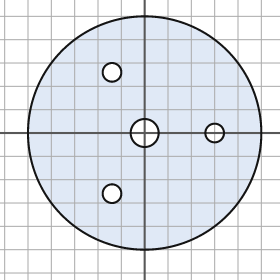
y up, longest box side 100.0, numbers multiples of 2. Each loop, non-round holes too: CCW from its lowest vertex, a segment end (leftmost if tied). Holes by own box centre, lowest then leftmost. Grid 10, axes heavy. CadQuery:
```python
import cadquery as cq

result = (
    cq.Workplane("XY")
    .moveTo(0.0, 0.0)
    .circle(50.0)
    .moveTo(-14.0, -26.0)
    .circle(4.0)
    .moveTo(0.0, 0.0)
    .circle(6.0)
    .moveTo(30.0, 0.0)
    .circle(4.0)
    .moveTo(-14.0, 26.0)
    .circle(4.0)
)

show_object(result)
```